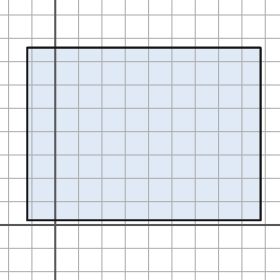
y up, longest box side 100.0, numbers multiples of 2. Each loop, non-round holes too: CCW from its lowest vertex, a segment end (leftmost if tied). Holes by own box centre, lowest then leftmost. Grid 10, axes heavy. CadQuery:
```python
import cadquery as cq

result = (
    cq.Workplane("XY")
    .moveTo(-12.0, 2.0)
    .lineTo(88.0, 2.0)
    .lineTo(88.0, 76.0)
    .lineTo(-12.0, 76.0)
    .close()
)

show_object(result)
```